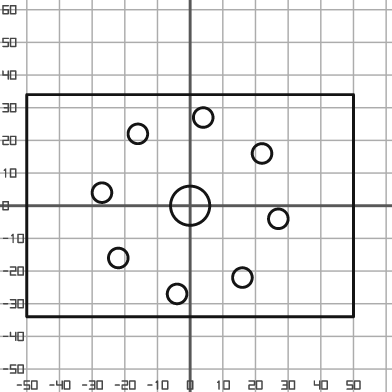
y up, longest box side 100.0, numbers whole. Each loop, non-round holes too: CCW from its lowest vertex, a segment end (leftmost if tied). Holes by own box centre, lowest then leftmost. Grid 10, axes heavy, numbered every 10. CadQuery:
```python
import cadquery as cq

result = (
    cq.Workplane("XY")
    .moveTo(-50.0, -34.0)
    .lineTo(50.0, -34.0)
    .lineTo(50.0, 34.0)
    .lineTo(-50.0, 34.0)
    .close()
    .moveTo(-4.0, -27.0)
    .circle(3.0)
    .moveTo(16.0, -22.0)
    .circle(3.0)
    .moveTo(-22.0, -16.0)
    .circle(3.0)
    .moveTo(27.0, -4.0)
    .circle(3.0)
    .moveTo(0.0, 0.0)
    .circle(6.0)
    .moveTo(-27.0, 4.0)
    .circle(3.0)
    .moveTo(22.0, 16.0)
    .circle(3.0)
    .moveTo(-16.0, 22.0)
    .circle(3.0)
    .moveTo(4.0, 27.0)
    .circle(3.0)
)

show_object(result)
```